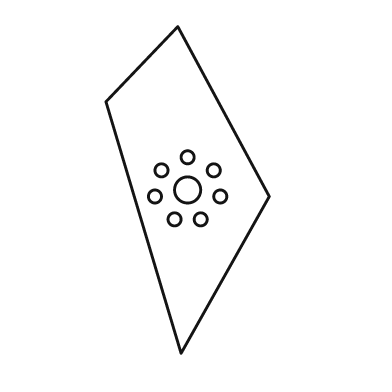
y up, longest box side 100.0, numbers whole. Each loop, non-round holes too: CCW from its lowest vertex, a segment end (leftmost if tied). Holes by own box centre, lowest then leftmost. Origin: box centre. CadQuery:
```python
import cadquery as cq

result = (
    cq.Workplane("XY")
    .moveTo(-2.0, -50.0)
    .lineTo(25.0, -2.0)
    .lineTo(-3.0, 50.0)
    .lineTo(-25.0, 27.0)
    .close()
    .moveTo(-4.0, -9.0)
    .circle(2.0)
    .moveTo(4.0, -9.0)
    .circle(2.0)
    .moveTo(-10.0, -2.0)
    .circle(2.0)
    .moveTo(10.0, -2.0)
    .circle(2.0)
    .moveTo(0.0, 0.0)
    .circle(4.0)
    .moveTo(-8.0, 6.0)
    .circle(2.0)
    .moveTo(8.0, 6.0)
    .circle(2.0)
    .moveTo(0.0, 10.0)
    .circle(2.0)
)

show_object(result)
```